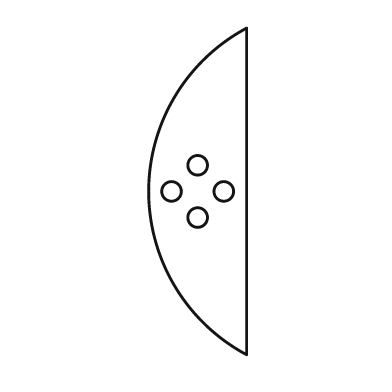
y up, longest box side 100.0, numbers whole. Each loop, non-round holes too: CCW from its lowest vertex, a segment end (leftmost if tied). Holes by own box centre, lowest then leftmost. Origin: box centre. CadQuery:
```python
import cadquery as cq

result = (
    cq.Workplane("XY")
    .moveTo(15.0, -50.0)
    .lineTo(15.0, 50.0)
    .threePointArc((-15.0, 0.0), (15.0, -50.0))
    .close()
    .moveTo(0.0, -8.0)
    .circle(3.0)
    .moveTo(-8.0, 0.0)
    .circle(3.0)
    .moveTo(8.0, 0.0)
    .circle(3.0)
    .moveTo(0.0, 8.0)
    .circle(3.0)
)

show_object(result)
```